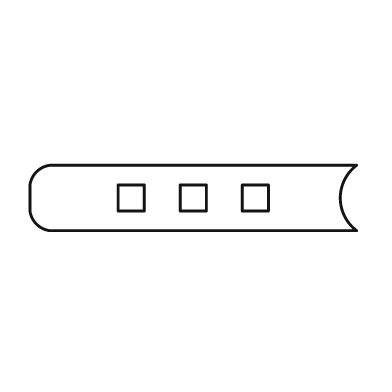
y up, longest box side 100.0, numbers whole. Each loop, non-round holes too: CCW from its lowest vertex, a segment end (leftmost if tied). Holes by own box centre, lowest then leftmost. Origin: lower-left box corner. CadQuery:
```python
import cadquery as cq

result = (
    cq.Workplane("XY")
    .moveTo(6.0, 0.0)
    .lineTo(100.0, 0.0)
    .threePointArc((95.0, 10.0), (100.0, 20.0))
    .lineTo(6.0, 20.0)
    .threePointArc((2.0, 18.0), (0.0, 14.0))
    .lineTo(0.0, 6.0)
    .threePointArc((2.0, 2.0), (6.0, 0.0))
    .close()
    .moveTo(27.0, 6.0)
    .lineTo(35.0, 6.0)
    .lineTo(35.0, 14.0)
    .lineTo(27.0, 14.0)
    .close()
    .moveTo(46.0, 6.0)
    .lineTo(54.0, 6.0)
    .lineTo(54.0, 14.0)
    .lineTo(46.0, 14.0)
    .close()
    .moveTo(65.0, 6.0)
    .lineTo(73.0, 6.0)
    .lineTo(73.0, 14.0)
    .lineTo(65.0, 14.0)
    .close()
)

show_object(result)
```